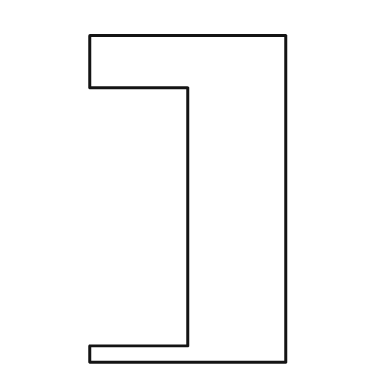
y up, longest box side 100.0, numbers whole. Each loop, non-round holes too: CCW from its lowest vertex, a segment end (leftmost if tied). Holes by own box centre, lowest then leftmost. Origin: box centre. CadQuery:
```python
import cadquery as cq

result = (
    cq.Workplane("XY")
    .moveTo(-30.0, -50.0)
    .lineTo(30.0, -50.0)
    .lineTo(30.0, 50.0)
    .lineTo(-30.0, 50.0)
    .lineTo(-30.0, 34.0)
    .lineTo(0.0, 34.0)
    .lineTo(0.0, -45.0)
    .lineTo(-30.0, -45.0)
    .close()
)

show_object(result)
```